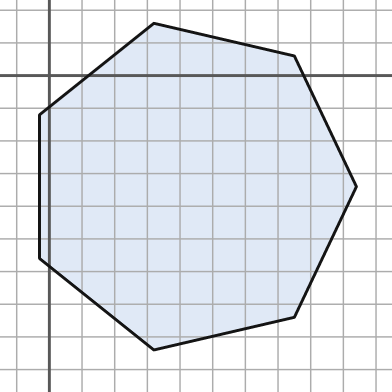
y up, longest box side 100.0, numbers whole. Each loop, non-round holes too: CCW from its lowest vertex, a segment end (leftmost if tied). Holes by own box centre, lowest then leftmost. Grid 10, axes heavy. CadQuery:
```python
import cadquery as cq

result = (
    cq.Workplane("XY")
    .moveTo(32.0, -84.0)
    .lineTo(75.0, -74.0)
    .lineTo(94.0, -34.0)
    .lineTo(75.0, 6.0)
    .lineTo(32.0, 16.0)
    .lineTo(-3.0, -12.0)
    .lineTo(-3.0, -56.0)
    .close()
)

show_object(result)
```